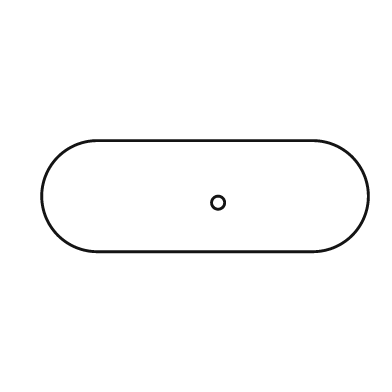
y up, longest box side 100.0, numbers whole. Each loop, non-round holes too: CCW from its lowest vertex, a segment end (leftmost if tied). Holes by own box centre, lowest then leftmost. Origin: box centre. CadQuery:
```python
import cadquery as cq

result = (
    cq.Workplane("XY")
    .moveTo(-33.0, -17.0)
    .lineTo(33.0, -17.0)
    .threePointArc((50.0, 0.0), (33.0, 17.0))
    .lineTo(-33.0, 17.0)
    .threePointArc((-50.0, 0.0), (-33.0, -17.0))
    .close()
    .moveTo(4.0, -2.0)
    .circle(2.0)
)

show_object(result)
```